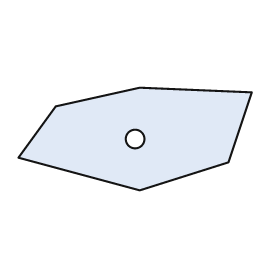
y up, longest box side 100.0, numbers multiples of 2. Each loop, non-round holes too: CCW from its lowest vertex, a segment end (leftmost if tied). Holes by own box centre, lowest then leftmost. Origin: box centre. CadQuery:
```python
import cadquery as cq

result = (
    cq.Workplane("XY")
    .moveTo(2.0, -22.0)
    .lineTo(40.0, -10.0)
    .lineTo(50.0, 20.0)
    .lineTo(2.0, 22.0)
    .lineTo(-34.0, 14.0)
    .lineTo(-50.0, -8.0)
    .close()
    .moveTo(0.0, 0.0)
    .circle(4.0)
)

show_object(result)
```